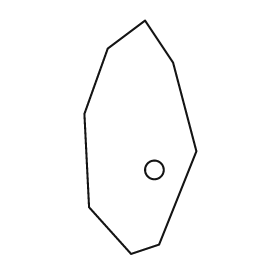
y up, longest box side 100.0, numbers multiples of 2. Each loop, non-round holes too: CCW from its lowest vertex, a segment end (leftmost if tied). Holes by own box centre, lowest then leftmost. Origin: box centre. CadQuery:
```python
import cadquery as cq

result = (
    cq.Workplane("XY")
    .moveTo(-4.0, -50.0)
    .lineTo(8.0, -46.0)
    .lineTo(24.0, -6.0)
    .lineTo(14.0, 32.0)
    .lineTo(2.0, 50.0)
    .lineTo(-14.0, 38.0)
    .lineTo(-24.0, 10.0)
    .lineTo(-22.0, -30.0)
    .close()
    .moveTo(6.0, -14.0)
    .circle(4.0)
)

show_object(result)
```